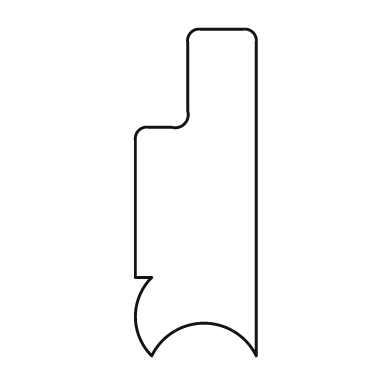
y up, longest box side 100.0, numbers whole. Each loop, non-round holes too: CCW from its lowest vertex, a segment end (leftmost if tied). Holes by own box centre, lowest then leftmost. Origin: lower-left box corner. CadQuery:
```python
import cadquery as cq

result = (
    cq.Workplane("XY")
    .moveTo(5.0, 0.0)
    .threePointArc((21.0, 10.0), (37.0, 0.0))
    .lineTo(37.0, 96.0)
    .threePointArc((36.0, 99.0), (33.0, 100.0))
    .lineTo(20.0, 100.0)
    .threePointArc((17.0, 99.0), (16.0, 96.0))
    .lineTo(16.0, 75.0)
    .threePointArc((15.0, 71.0), (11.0, 70.0))
    .lineTo(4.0, 70.0)
    .threePointArc((1.0, 69.0), (0.0, 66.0))
    .lineTo(0.0, 24.0)
    .lineTo(5.0, 24.0)
    .threePointArc((0.0, 12.0), (5.0, 0.0))
    .close()
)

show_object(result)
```